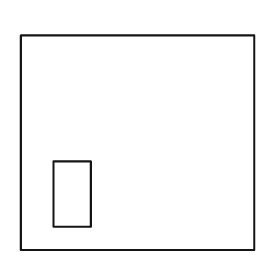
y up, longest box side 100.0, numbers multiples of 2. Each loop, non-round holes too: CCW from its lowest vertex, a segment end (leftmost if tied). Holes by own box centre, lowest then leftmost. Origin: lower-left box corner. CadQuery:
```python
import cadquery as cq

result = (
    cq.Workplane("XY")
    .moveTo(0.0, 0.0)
    .lineTo(100.0, 0.0)
    .lineTo(100.0, 92.0)
    .lineTo(0.0, 92.0)
    .close()
    .moveTo(14.0, 10.0)
    .lineTo(30.0, 10.0)
    .lineTo(30.0, 38.0)
    .lineTo(14.0, 38.0)
    .close()
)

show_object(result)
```